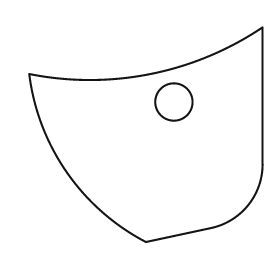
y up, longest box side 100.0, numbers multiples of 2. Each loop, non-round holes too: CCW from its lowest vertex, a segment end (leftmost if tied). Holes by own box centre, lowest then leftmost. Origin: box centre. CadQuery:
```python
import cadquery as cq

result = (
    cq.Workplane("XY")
    .moveTo(0.0, -46.0)
    .lineTo(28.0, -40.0)
    .threePointArc((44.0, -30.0), (50.0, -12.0))
    .lineTo(50.0, 46.0)
    .threePointArc((2.0, 26.0), (-50.0, 26.0))
    .threePointArc((-34.0, -16.0), (0.0, -46.0))
    .close()
    .moveTo(12.0, 14.0)
    .circle(8.0)
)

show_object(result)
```